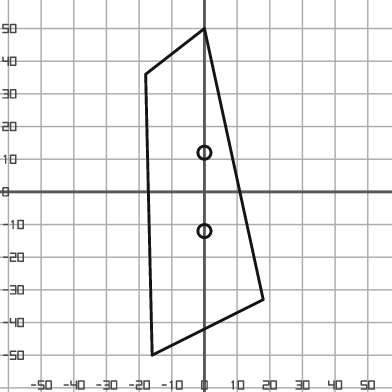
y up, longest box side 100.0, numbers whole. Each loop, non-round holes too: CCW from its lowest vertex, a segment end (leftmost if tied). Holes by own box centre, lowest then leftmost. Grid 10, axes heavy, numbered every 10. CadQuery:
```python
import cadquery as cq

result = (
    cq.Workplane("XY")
    .moveTo(-16.0, -50.0)
    .lineTo(18.0, -33.0)
    .lineTo(0.0, 50.0)
    .lineTo(-18.0, 36.0)
    .close()
    .moveTo(0.0, -12.0)
    .circle(2.0)
    .moveTo(0.0, 12.0)
    .circle(2.0)
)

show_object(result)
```